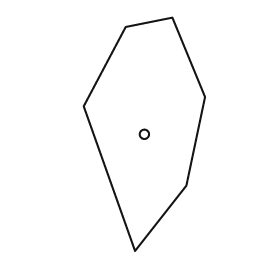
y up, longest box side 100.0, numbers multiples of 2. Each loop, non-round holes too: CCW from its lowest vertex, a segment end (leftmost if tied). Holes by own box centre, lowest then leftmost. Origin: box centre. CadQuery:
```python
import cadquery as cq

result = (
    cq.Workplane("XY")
    .moveTo(-4.0, -50.0)
    .lineTo(18.0, -22.0)
    .lineTo(26.0, 16.0)
    .lineTo(12.0, 50.0)
    .lineTo(-8.0, 46.0)
    .lineTo(-26.0, 12.0)
    .close()
    .moveTo(0.0, 0.0)
    .circle(2.0)
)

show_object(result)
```